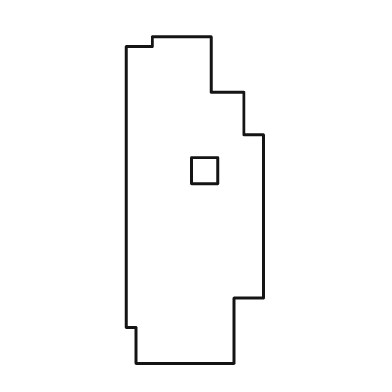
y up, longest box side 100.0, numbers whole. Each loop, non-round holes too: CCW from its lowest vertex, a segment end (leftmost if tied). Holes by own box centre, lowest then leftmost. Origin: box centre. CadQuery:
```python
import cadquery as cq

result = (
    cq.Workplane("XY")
    .moveTo(-18.0, -50.0)
    .lineTo(12.0, -50.0)
    .lineTo(12.0, -30.0)
    .lineTo(21.0, -30.0)
    .lineTo(21.0, 20.0)
    .lineTo(15.0, 20.0)
    .lineTo(15.0, 33.0)
    .lineTo(5.0, 33.0)
    .lineTo(5.0, 50.0)
    .lineTo(-13.0, 50.0)
    .lineTo(-13.0, 47.0)
    .lineTo(-21.0, 47.0)
    .lineTo(-21.0, -39.0)
    .lineTo(-18.0, -39.0)
    .close()
    .moveTo(-1.0, 5.0)
    .lineTo(7.0, 5.0)
    .lineTo(7.0, 13.0)
    .lineTo(-1.0, 13.0)
    .close()
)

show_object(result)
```